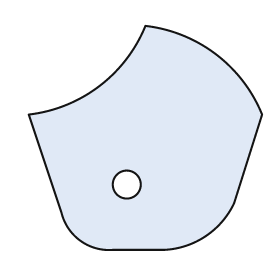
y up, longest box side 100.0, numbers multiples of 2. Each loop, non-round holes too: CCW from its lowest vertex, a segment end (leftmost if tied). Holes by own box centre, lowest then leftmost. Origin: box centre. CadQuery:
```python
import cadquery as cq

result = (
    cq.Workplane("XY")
    .moveTo(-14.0, -48.0)
    .lineTo(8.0, -48.0)
    .threePointArc((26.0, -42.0), (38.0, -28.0))
    .lineTo(50.0, 10.0)
    .threePointArc((30.0, 36.0), (0.0, 48.0))
    .threePointArc((-20.0, 22.0), (-50.0, 10.0))
    .lineTo(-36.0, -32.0)
    .threePointArc((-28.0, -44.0), (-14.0, -48.0))
    .close()
    .moveTo(-8.0, -20.0)
    .circle(6.0)
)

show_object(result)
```